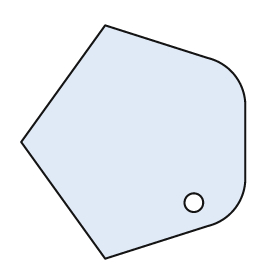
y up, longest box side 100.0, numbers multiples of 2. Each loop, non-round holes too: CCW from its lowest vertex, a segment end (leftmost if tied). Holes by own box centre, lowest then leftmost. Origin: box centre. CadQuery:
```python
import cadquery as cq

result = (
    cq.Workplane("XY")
    .moveTo(-12.0, -50.0)
    .lineTo(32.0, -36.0)
    .threePointArc((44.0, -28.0), (48.0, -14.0))
    .lineTo(48.0, 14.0)
    .threePointArc((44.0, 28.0), (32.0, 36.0))
    .lineTo(-12.0, 50.0)
    .lineTo(-48.0, 0.0)
    .close()
    .moveTo(26.0, -26.0)
    .circle(4.0)
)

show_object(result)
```